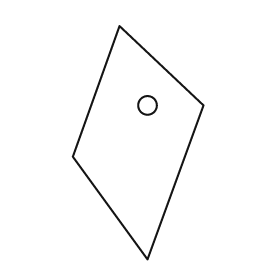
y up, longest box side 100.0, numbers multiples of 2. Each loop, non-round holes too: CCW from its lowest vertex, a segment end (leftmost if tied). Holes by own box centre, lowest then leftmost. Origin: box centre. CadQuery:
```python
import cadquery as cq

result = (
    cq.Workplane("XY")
    .moveTo(4.0, -50.0)
    .lineTo(28.0, 16.0)
    .lineTo(-8.0, 50.0)
    .lineTo(-28.0, -6.0)
    .close()
    .moveTo(4.0, 16.0)
    .circle(4.0)
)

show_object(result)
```